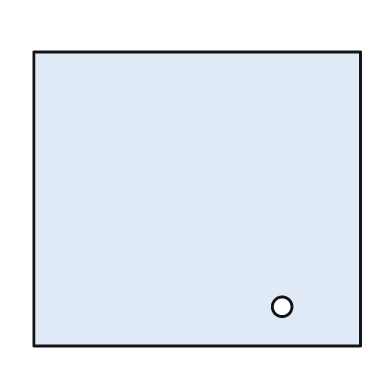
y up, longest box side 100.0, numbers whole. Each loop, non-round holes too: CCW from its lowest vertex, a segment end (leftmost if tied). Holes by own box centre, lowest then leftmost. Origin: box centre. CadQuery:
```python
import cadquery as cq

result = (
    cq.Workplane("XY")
    .moveTo(-50.0, -45.0)
    .lineTo(50.0, -45.0)
    .lineTo(50.0, 45.0)
    .lineTo(-50.0, 45.0)
    .close()
    .moveTo(26.0, -33.0)
    .circle(3.0)
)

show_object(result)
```